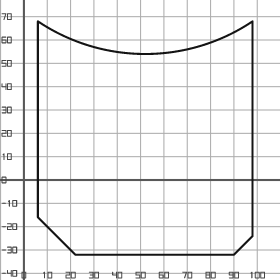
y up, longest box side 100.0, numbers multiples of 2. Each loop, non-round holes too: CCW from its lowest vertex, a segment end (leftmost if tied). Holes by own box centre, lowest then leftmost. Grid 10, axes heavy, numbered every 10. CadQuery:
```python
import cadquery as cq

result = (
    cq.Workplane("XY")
    .moveTo(22.0, -32.0)
    .lineTo(90.0, -32.0)
    .lineTo(98.0, -24.0)
    .lineTo(98.0, 68.0)
    .threePointArc((52.0, 54.0), (6.0, 68.0))
    .lineTo(6.0, -16.0)
    .close()
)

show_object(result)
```